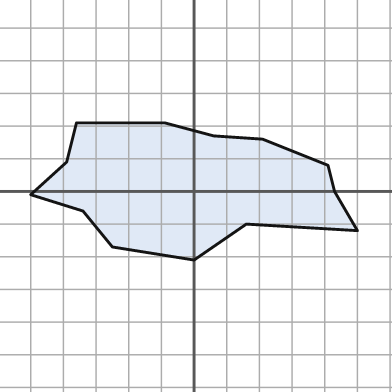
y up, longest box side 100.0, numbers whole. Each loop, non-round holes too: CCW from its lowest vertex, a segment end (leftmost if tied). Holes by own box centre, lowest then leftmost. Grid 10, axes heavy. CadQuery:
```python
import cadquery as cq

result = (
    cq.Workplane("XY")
    .moveTo(0.0, -21.0)
    .lineTo(16.0, -10.0)
    .lineTo(50.0, -12.0)
    .lineTo(43.0, 0.0)
    .lineTo(41.0, 8.0)
    .lineTo(21.0, 16.0)
    .lineTo(6.0, 17.0)
    .lineTo(-9.0, 21.0)
    .lineTo(-36.0, 21.0)
    .lineTo(-39.0, 9.0)
    .lineTo(-50.0, -1.0)
    .lineTo(-34.0, -6.0)
    .lineTo(-25.0, -17.0)
    .close()
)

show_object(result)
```